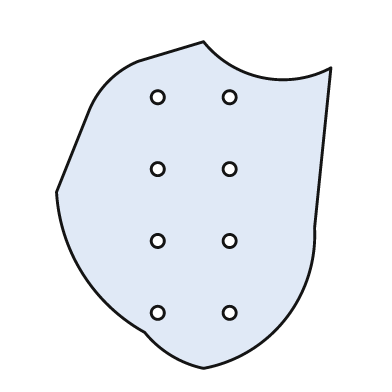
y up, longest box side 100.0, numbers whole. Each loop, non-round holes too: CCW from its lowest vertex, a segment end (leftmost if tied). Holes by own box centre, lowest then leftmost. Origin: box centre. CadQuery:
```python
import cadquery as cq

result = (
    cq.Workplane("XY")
    .moveTo(3.0, -50.0)
    .threePointArc((28.0, -35.0), (37.0, -7.0))
    .lineTo(42.0, 42.0)
    .threePointArc((21.0, 39.0), (3.0, 50.0))
    .lineTo(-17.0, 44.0)
    .threePointArc((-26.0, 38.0), (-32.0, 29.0))
    .lineTo(-42.0, 4.0)
    .threePointArc((-34.0, -21.0), (-15.0, -39.0))
    .threePointArc((-7.0, -46.0), (3.0, -50.0))
    .close()
    .moveTo(-11.0, -33.0)
    .circle(2.0)
    .moveTo(11.0, -33.0)
    .circle(2.0)
    .moveTo(-11.0, -11.0)
    .circle(2.0)
    .moveTo(11.0, -11.0)
    .circle(2.0)
    .moveTo(-11.0, 11.0)
    .circle(2.0)
    .moveTo(11.0, 11.0)
    .circle(2.0)
    .moveTo(-11.0, 33.0)
    .circle(2.0)
    .moveTo(11.0, 33.0)
    .circle(2.0)
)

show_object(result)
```